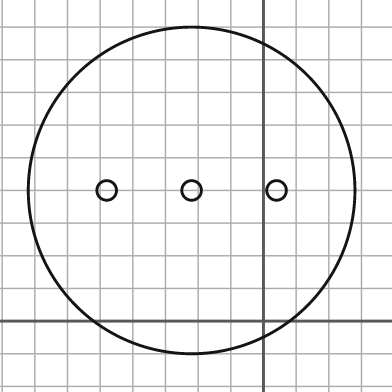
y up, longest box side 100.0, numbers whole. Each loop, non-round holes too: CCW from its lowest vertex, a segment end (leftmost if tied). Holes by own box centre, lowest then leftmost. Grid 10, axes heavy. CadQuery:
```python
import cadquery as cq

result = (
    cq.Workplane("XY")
    .moveTo(-22.0, 40.0)
    .circle(50.0)
    .moveTo(-48.0, 40.0)
    .circle(3.0)
    .moveTo(-22.0, 40.0)
    .circle(3.0)
    .moveTo(4.0, 40.0)
    .circle(3.0)
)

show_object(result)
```